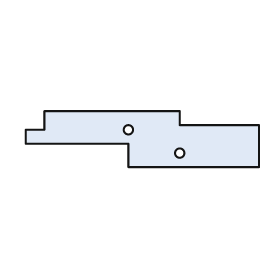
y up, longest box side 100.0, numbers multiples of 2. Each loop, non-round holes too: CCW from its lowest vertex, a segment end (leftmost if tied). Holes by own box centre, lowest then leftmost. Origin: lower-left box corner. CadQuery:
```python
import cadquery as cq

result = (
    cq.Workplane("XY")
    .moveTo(44.0, 0.0)
    .lineTo(100.0, 0.0)
    .lineTo(100.0, 18.0)
    .lineTo(66.0, 18.0)
    .lineTo(66.0, 24.0)
    .lineTo(8.0, 24.0)
    .lineTo(8.0, 16.0)
    .lineTo(0.0, 16.0)
    .lineTo(0.0, 10.0)
    .lineTo(44.0, 10.0)
    .close()
    .moveTo(66.0, 6.0)
    .circle(2.0)
    .moveTo(44.0, 16.0)
    .circle(2.0)
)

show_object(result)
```